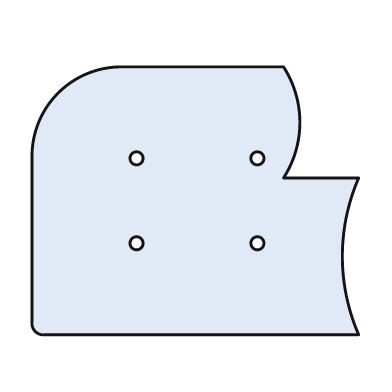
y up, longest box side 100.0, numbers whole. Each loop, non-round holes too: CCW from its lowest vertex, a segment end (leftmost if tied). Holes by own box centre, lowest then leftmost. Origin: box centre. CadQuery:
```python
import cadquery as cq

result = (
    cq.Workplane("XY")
    .moveTo(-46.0, -41.0)
    .lineTo(50.0, -41.0)
    .threePointArc((45.0, -17.0), (50.0, 7.0))
    .lineTo(27.0, 7.0)
    .threePointArc((32.0, 24.0), (27.0, 41.0))
    .lineTo(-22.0, 41.0)
    .threePointArc((-42.0, 33.0), (-50.0, 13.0))
    .lineTo(-50.0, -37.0)
    .threePointArc((-49.0, -40.0), (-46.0, -41.0))
    .close()
    .moveTo(-18.0, -13.0)
    .circle(2.0)
    .moveTo(19.0, -13.0)
    .circle(2.0)
    .moveTo(-18.0, 13.0)
    .circle(2.0)
    .moveTo(19.0, 13.0)
    .circle(2.0)
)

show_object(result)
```